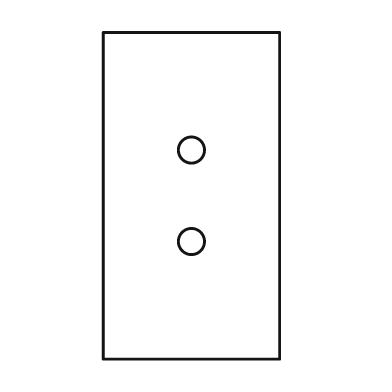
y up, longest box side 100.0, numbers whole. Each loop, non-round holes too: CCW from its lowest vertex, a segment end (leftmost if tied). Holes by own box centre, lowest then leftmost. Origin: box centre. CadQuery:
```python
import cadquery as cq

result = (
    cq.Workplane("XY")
    .moveTo(-27.0, -50.0)
    .lineTo(27.0, -50.0)
    .lineTo(27.0, 50.0)
    .lineTo(-27.0, 50.0)
    .close()
    .moveTo(0.0, -14.0)
    .circle(4.0)
    .moveTo(0.0, 14.0)
    .circle(4.0)
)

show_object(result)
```